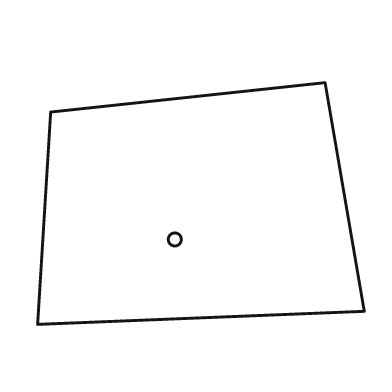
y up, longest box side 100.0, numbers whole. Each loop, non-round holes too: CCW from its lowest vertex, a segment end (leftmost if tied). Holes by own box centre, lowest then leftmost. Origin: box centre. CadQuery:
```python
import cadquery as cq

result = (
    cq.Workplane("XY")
    .moveTo(-50.0, -37.0)
    .lineTo(50.0, -33.0)
    .lineTo(38.0, 37.0)
    .lineTo(-46.0, 28.0)
    .close()
    .moveTo(-8.0, -11.0)
    .circle(2.0)
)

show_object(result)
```